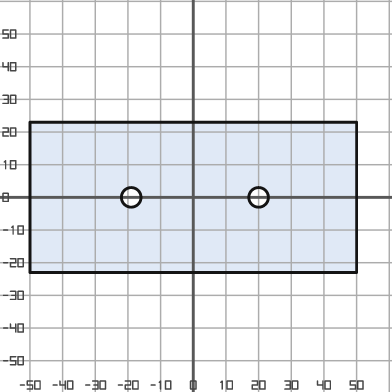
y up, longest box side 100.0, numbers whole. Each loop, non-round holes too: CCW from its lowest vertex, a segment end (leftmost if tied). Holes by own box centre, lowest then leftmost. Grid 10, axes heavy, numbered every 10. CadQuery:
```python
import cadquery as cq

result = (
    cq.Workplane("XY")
    .moveTo(-50.0, -23.0)
    .lineTo(50.0, -23.0)
    .lineTo(50.0, 23.0)
    .lineTo(-50.0, 23.0)
    .close()
    .moveTo(-19.0, 0.0)
    .circle(3.0)
    .moveTo(20.0, 0.0)
    .circle(3.0)
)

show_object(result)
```